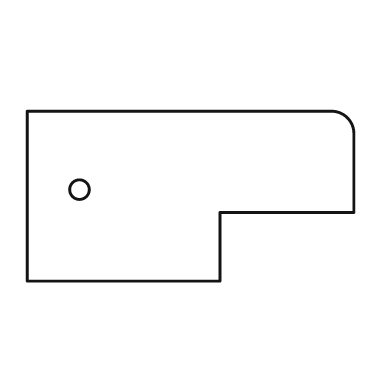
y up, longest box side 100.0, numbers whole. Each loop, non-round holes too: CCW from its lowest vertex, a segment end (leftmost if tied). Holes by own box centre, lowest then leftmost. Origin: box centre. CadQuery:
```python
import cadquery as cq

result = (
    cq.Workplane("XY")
    .moveTo(-50.0, -26.0)
    .lineTo(9.0, -26.0)
    .lineTo(9.0, -5.0)
    .lineTo(50.0, -5.0)
    .lineTo(50.0, 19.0)
    .threePointArc((48.0, 24.0), (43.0, 26.0))
    .lineTo(-50.0, 26.0)
    .close()
    .moveTo(-34.0, 2.0)
    .circle(3.0)
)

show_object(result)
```